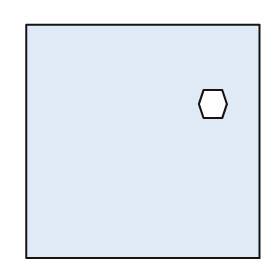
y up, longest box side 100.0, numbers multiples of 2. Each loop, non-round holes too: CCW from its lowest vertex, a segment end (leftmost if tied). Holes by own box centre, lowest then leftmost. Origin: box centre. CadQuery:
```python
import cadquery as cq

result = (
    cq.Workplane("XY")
    .moveTo(-50.0, -50.0)
    .lineTo(50.0, -50.0)
    .lineTo(50.0, 50.0)
    .lineTo(-50.0, 50.0)
    .close()
    .moveTo(26.0, 10.0)
    .lineTo(34.0, 10.0)
    .lineTo(36.0, 16.0)
    .lineTo(34.0, 22.0)
    .lineTo(26.0, 22.0)
    .lineTo(24.0, 16.0)
    .close()
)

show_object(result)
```